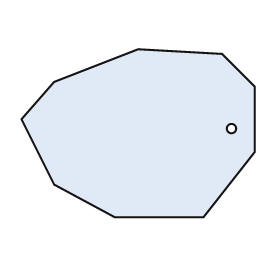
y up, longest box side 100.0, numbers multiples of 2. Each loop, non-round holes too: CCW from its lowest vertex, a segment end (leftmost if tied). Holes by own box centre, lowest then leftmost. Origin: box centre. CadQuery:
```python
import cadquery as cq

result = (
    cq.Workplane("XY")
    .moveTo(-10.0, -36.0)
    .lineTo(28.0, -36.0)
    .lineTo(50.0, -8.0)
    .lineTo(50.0, 20.0)
    .lineTo(36.0, 34.0)
    .lineTo(0.0, 36.0)
    .lineTo(-36.0, 22.0)
    .lineTo(-50.0, 6.0)
    .lineTo(-36.0, -22.0)
    .close()
    .moveTo(40.0, 2.0)
    .circle(2.0)
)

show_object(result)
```